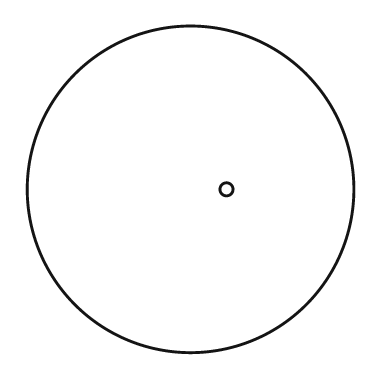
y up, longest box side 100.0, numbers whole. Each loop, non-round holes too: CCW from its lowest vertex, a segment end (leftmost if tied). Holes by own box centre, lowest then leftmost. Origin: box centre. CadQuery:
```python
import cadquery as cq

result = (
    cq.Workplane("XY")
    .moveTo(0.0, 0.0)
    .circle(50.0)
    .moveTo(11.0, 0.0)
    .circle(2.0)
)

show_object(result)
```